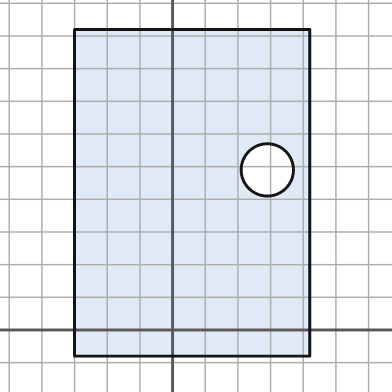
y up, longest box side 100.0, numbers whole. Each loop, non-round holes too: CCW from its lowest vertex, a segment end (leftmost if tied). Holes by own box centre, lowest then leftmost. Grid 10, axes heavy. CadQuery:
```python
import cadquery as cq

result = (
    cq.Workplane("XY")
    .moveTo(-30.0, -8.0)
    .lineTo(42.0, -8.0)
    .lineTo(42.0, 92.0)
    .lineTo(-30.0, 92.0)
    .close()
    .moveTo(29.0, 49.0)
    .circle(8.0)
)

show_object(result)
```